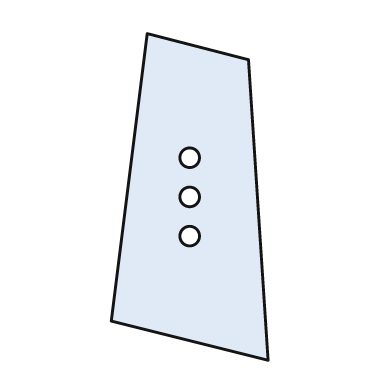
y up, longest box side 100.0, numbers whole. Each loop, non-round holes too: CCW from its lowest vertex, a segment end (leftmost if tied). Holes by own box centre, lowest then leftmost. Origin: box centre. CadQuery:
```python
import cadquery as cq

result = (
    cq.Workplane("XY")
    .moveTo(24.0, -50.0)
    .lineTo(18.0, 42.0)
    .lineTo(-13.0, 50.0)
    .lineTo(-24.0, -38.0)
    .close()
    .moveTo(0.0, -12.0)
    .circle(3.0)
    .moveTo(0.0, 0.0)
    .circle(3.0)
    .moveTo(0.0, 12.0)
    .circle(3.0)
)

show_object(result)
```